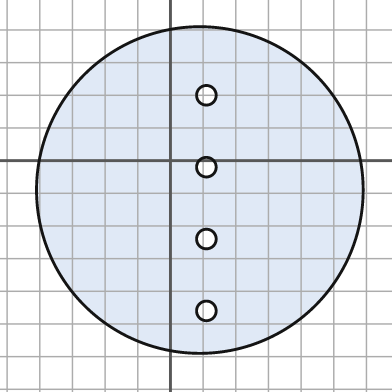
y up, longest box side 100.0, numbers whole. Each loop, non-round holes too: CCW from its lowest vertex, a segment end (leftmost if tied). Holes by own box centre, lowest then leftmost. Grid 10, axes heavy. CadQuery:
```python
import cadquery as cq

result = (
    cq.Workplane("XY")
    .moveTo(9.0, -9.0)
    .circle(50.0)
    .moveTo(11.0, -46.0)
    .circle(3.0)
    .moveTo(11.0, -24.0)
    .circle(3.0)
    .moveTo(11.0, -2.0)
    .circle(3.0)
    .moveTo(11.0, 20.0)
    .circle(3.0)
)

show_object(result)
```